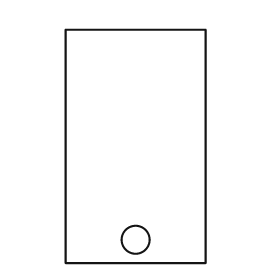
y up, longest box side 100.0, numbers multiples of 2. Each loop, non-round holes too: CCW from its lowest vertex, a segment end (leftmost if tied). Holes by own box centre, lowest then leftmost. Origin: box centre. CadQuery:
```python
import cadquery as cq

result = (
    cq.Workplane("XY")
    .moveTo(-30.0, -50.0)
    .lineTo(30.0, -50.0)
    .lineTo(30.0, 50.0)
    .lineTo(-30.0, 50.0)
    .close()
    .moveTo(0.0, -40.0)
    .circle(6.0)
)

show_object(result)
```